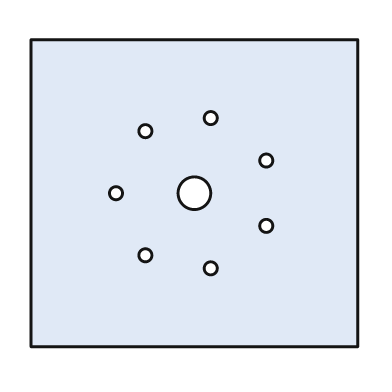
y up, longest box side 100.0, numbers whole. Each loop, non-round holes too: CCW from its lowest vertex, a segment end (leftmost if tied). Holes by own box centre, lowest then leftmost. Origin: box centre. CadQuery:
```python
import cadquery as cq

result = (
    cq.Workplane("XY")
    .moveTo(-50.0, -47.0)
    .lineTo(50.0, -47.0)
    .lineTo(50.0, 47.0)
    .lineTo(-50.0, 47.0)
    .close()
    .moveTo(5.0, -23.0)
    .circle(2.0)
    .moveTo(-15.0, -19.0)
    .circle(2.0)
    .moveTo(22.0, -10.0)
    .circle(2.0)
    .moveTo(-24.0, 0.0)
    .circle(2.0)
    .moveTo(0.0, 0.0)
    .circle(5.0)
    .moveTo(22.0, 10.0)
    .circle(2.0)
    .moveTo(-15.0, 19.0)
    .circle(2.0)
    .moveTo(5.0, 23.0)
    .circle(2.0)
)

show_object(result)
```